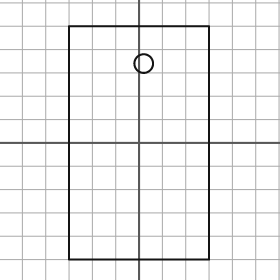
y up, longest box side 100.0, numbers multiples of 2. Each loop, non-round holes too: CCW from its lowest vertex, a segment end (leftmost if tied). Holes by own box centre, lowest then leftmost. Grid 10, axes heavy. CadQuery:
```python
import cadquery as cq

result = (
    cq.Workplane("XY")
    .moveTo(-30.0, -50.0)
    .lineTo(30.0, -50.0)
    .lineTo(30.0, 50.0)
    .lineTo(-30.0, 50.0)
    .close()
    .moveTo(2.0, 34.0)
    .circle(4.0)
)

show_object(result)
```